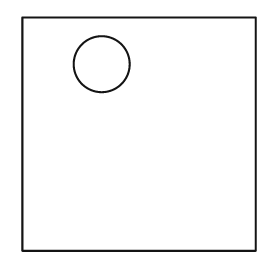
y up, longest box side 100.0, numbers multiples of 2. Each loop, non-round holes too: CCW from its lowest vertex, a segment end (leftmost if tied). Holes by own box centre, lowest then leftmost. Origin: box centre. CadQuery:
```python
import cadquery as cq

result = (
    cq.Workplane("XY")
    .moveTo(-50.0, -50.0)
    .lineTo(50.0, -50.0)
    .lineTo(50.0, 50.0)
    .lineTo(-50.0, 50.0)
    .close()
    .moveTo(-16.0, 30.0)
    .circle(12.0)
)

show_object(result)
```